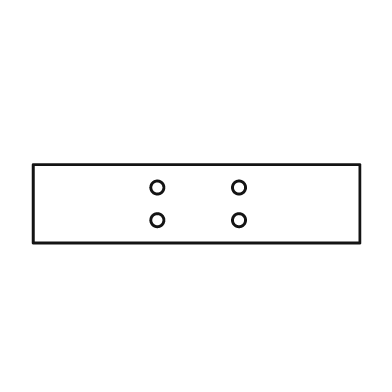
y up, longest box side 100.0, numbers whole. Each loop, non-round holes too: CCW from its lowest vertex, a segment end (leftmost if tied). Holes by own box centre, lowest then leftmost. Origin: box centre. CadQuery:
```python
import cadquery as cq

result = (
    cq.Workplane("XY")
    .moveTo(-50.0, -12.0)
    .lineTo(50.0, -12.0)
    .lineTo(50.0, 12.0)
    .lineTo(-50.0, 12.0)
    .close()
    .moveTo(-12.0, -5.0)
    .circle(2.0)
    .moveTo(13.0, -5.0)
    .circle(2.0)
    .moveTo(-12.0, 5.0)
    .circle(2.0)
    .moveTo(13.0, 5.0)
    .circle(2.0)
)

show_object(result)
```